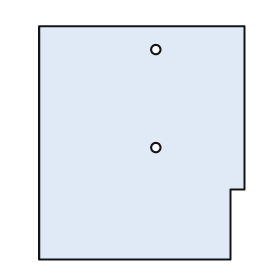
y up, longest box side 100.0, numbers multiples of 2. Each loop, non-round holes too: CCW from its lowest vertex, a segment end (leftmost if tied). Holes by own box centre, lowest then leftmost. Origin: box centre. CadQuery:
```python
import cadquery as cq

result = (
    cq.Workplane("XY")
    .moveTo(-44.0, -50.0)
    .lineTo(38.0, -50.0)
    .lineTo(38.0, -20.0)
    .lineTo(44.0, -20.0)
    .lineTo(44.0, 50.0)
    .lineTo(-44.0, 50.0)
    .close()
    .moveTo(6.0, -2.0)
    .circle(2.0)
    .moveTo(6.0, 40.0)
    .circle(2.0)
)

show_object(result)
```